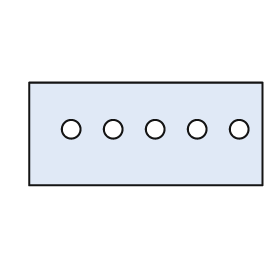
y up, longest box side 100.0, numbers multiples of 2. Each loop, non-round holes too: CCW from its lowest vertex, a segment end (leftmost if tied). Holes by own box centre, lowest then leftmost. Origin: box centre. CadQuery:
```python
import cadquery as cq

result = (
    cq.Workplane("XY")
    .moveTo(-50.0, -22.0)
    .lineTo(50.0, -22.0)
    .lineTo(50.0, 22.0)
    .lineTo(-50.0, 22.0)
    .close()
    .moveTo(-32.0, 2.0)
    .circle(4.0)
    .moveTo(-14.0, 2.0)
    .circle(4.0)
    .moveTo(4.0, 2.0)
    .circle(4.0)
    .moveTo(22.0, 2.0)
    .circle(4.0)
    .moveTo(40.0, 2.0)
    .circle(4.0)
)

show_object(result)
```